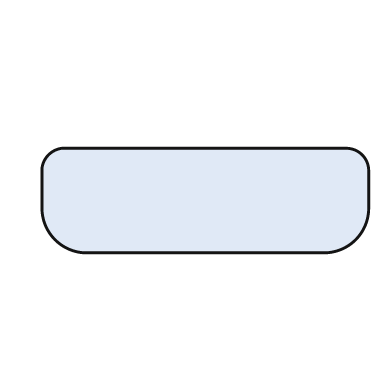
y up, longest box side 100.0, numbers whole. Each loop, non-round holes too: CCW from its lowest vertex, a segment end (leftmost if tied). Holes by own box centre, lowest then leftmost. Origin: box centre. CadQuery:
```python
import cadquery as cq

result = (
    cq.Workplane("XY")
    .moveTo(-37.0, -16.0)
    .lineTo(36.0, -16.0)
    .threePointArc((46.0, -12.0), (50.0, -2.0))
    .lineTo(50.0, 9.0)
    .threePointArc((48.0, 14.0), (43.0, 16.0))
    .lineTo(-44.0, 16.0)
    .threePointArc((-48.0, 14.0), (-50.0, 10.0))
    .lineTo(-50.0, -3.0)
    .threePointArc((-46.0, -12.0), (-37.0, -16.0))
    .close()
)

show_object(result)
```